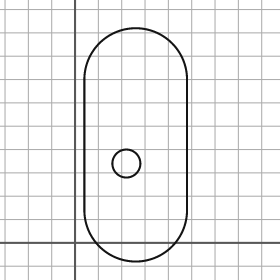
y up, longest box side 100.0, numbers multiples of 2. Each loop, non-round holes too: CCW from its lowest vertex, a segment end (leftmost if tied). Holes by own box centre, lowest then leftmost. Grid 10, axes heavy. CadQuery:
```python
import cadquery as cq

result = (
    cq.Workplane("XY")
    .moveTo(4.0, 14.0)
    .threePointArc((26.0, -8.0), (48.0, 14.0))
    .lineTo(48.0, 70.0)
    .threePointArc((26.0, 92.0), (4.0, 70.0))
    .close()
    .moveTo(22.0, 34.0)
    .circle(6.0)
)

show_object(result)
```